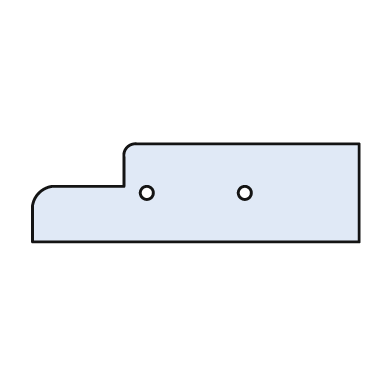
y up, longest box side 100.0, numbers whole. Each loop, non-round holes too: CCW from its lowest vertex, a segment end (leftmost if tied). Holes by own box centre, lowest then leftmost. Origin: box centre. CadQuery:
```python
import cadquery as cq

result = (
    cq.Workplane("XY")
    .moveTo(-50.0, -15.0)
    .lineTo(50.0, -15.0)
    .lineTo(50.0, 15.0)
    .lineTo(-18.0, 15.0)
    .threePointArc((-21.0, 14.0), (-22.0, 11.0))
    .lineTo(-22.0, 2.0)
    .lineTo(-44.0, 2.0)
    .threePointArc((-48.0, 0.0), (-50.0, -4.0))
    .close()
    .moveTo(-15.0, 0.0)
    .circle(2.0)
    .moveTo(15.0, 0.0)
    .circle(2.0)
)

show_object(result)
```